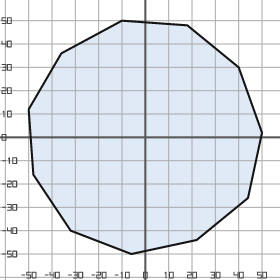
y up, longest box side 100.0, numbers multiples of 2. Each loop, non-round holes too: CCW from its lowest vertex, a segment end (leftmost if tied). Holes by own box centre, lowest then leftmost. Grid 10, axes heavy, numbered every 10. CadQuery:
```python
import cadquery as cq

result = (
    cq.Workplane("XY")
    .moveTo(-6.0, -50.0)
    .lineTo(22.0, -44.0)
    .lineTo(44.0, -26.0)
    .lineTo(50.0, 2.0)
    .lineTo(40.0, 30.0)
    .lineTo(18.0, 48.0)
    .lineTo(-10.0, 50.0)
    .lineTo(-36.0, 36.0)
    .lineTo(-50.0, 12.0)
    .lineTo(-48.0, -16.0)
    .lineTo(-32.0, -40.0)
    .close()
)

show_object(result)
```